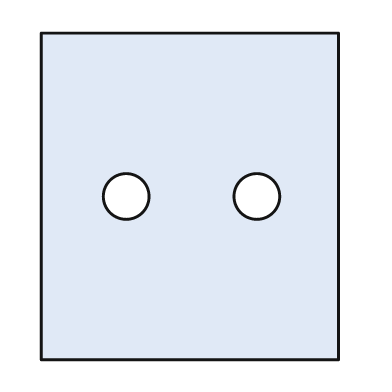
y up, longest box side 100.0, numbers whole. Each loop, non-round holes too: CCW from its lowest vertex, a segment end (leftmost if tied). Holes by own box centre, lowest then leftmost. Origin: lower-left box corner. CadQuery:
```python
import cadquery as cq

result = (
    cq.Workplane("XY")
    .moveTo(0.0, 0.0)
    .lineTo(91.0, 0.0)
    .lineTo(91.0, 100.0)
    .lineTo(0.0, 100.0)
    .close()
    .moveTo(26.0, 50.0)
    .circle(7.0)
    .moveTo(66.0, 50.0)
    .circle(7.0)
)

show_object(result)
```